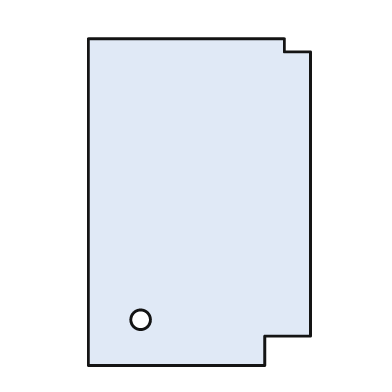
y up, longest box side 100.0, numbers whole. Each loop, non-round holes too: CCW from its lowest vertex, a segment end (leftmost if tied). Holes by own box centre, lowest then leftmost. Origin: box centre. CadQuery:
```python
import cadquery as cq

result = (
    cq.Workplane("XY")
    .moveTo(-34.0, -50.0)
    .lineTo(20.0, -50.0)
    .lineTo(20.0, -41.0)
    .lineTo(34.0, -41.0)
    .lineTo(34.0, 46.0)
    .lineTo(26.0, 46.0)
    .lineTo(26.0, 50.0)
    .lineTo(-34.0, 50.0)
    .close()
    .moveTo(-18.0, -36.0)
    .circle(3.0)
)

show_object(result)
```